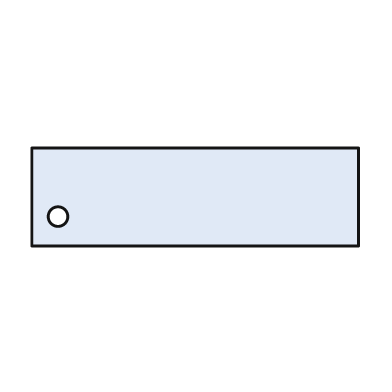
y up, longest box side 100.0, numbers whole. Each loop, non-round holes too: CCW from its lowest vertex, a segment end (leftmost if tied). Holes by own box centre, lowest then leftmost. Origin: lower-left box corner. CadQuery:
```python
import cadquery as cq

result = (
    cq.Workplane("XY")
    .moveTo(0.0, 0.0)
    .lineTo(100.0, 0.0)
    .lineTo(100.0, 30.0)
    .lineTo(0.0, 30.0)
    .close()
    .moveTo(8.0, 9.0)
    .circle(3.0)
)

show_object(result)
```